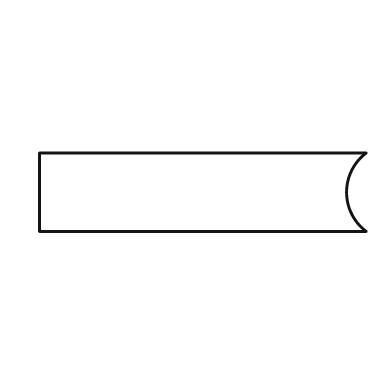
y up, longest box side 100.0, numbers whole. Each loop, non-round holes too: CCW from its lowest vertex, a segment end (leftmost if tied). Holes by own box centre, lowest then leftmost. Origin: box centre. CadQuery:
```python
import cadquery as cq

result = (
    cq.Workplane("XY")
    .moveTo(-50.0, -12.0)
    .lineTo(50.0, -12.0)
    .threePointArc((44.0, 0.0), (50.0, 12.0))
    .lineTo(-50.0, 12.0)
    .close()
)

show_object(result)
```